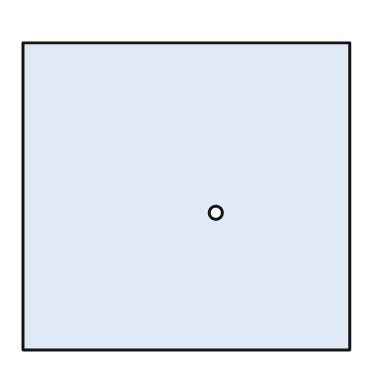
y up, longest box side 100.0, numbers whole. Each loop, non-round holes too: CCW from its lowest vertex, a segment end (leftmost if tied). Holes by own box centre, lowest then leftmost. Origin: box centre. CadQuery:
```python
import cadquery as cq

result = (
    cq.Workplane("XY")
    .moveTo(-50.0, -47.0)
    .lineTo(50.0, -47.0)
    .lineTo(50.0, 47.0)
    .lineTo(-50.0, 47.0)
    .close()
    .moveTo(9.0, -5.0)
    .circle(2.0)
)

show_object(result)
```